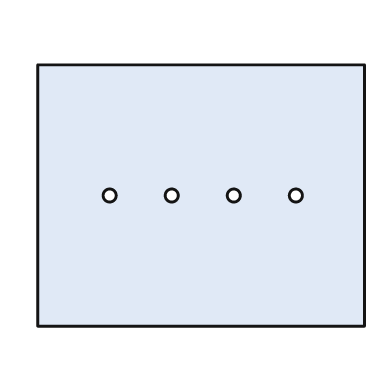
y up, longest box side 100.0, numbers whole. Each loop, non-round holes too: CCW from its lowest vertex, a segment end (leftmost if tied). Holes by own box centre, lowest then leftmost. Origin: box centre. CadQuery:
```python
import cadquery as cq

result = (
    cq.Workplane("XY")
    .moveTo(-50.0, -40.0)
    .lineTo(50.0, -40.0)
    .lineTo(50.0, 40.0)
    .lineTo(-50.0, 40.0)
    .close()
    .moveTo(-28.0, 0.0)
    .circle(2.0)
    .moveTo(-9.0, 0.0)
    .circle(2.0)
    .moveTo(10.0, 0.0)
    .circle(2.0)
    .moveTo(29.0, 0.0)
    .circle(2.0)
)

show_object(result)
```